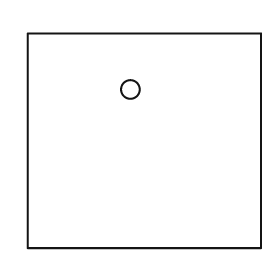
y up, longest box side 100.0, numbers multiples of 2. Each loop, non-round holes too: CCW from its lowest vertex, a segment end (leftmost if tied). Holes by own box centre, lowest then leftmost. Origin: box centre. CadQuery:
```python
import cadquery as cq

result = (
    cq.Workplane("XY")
    .moveTo(-50.0, -46.0)
    .lineTo(50.0, -46.0)
    .lineTo(50.0, 46.0)
    .lineTo(-50.0, 46.0)
    .close()
    .moveTo(-6.0, 22.0)
    .circle(4.0)
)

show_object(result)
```